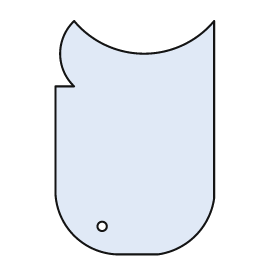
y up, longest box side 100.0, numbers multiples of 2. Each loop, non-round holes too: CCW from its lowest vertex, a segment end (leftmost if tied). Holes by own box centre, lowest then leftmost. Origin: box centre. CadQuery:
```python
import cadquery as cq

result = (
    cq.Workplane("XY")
    .moveTo(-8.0, -50.0)
    .lineTo(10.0, -50.0)
    .threePointArc((26.0, -42.0), (34.0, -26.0))
    .lineTo(34.0, 50.0)
    .threePointArc((4.0, 36.0), (-26.0, 50.0))
    .threePointArc((-32.0, 36.0), (-26.0, 22.0))
    .lineTo(-34.0, 22.0)
    .lineTo(-34.0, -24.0)
    .threePointArc((-26.0, -42.0), (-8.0, -50.0))
    .close()
    .moveTo(-14.0, -38.0)
    .circle(2.0)
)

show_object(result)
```